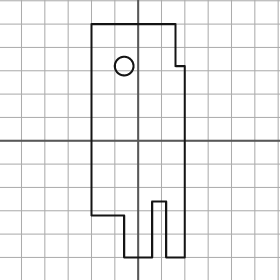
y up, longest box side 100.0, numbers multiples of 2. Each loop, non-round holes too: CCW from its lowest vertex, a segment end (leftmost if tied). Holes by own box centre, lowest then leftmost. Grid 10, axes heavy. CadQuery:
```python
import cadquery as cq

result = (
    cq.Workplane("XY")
    .moveTo(-6.0, -50.0)
    .lineTo(6.0, -50.0)
    .lineTo(6.0, -26.0)
    .lineTo(12.0, -26.0)
    .lineTo(12.0, -50.0)
    .lineTo(20.0, -50.0)
    .lineTo(20.0, 32.0)
    .lineTo(16.0, 32.0)
    .lineTo(16.0, 50.0)
    .lineTo(-20.0, 50.0)
    .lineTo(-20.0, -32.0)
    .lineTo(-6.0, -32.0)
    .close()
    .moveTo(-6.0, 32.0)
    .circle(4.0)
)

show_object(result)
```